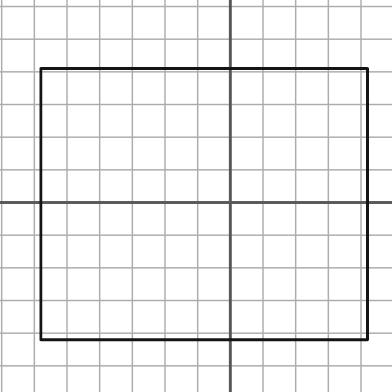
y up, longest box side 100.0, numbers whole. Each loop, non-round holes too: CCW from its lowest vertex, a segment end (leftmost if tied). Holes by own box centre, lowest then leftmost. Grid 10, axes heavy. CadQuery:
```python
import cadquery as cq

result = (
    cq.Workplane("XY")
    .moveTo(-58.0, -42.0)
    .lineTo(42.0, -42.0)
    .lineTo(42.0, 41.0)
    .lineTo(-58.0, 41.0)
    .close()
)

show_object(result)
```